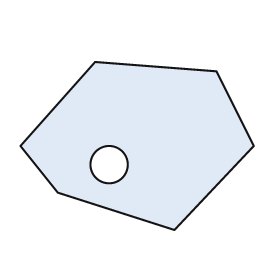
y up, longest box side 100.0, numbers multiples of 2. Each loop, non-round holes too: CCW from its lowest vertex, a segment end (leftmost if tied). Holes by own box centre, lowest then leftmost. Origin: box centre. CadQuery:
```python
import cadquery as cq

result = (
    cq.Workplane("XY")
    .moveTo(16.0, -36.0)
    .lineTo(50.0, 0.0)
    .lineTo(34.0, 32.0)
    .lineTo(-18.0, 36.0)
    .lineTo(-50.0, 0.0)
    .lineTo(-34.0, -20.0)
    .close()
    .moveTo(-12.0, -8.0)
    .circle(8.0)
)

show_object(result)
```